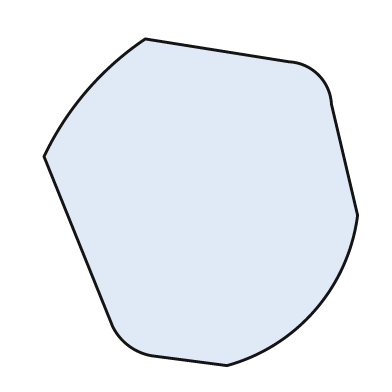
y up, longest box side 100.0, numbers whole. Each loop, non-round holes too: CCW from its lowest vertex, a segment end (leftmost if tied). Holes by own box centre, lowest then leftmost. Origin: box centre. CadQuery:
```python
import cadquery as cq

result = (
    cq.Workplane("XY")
    .moveTo(8.0, -50.0)
    .threePointArc((35.0, -33.0), (48.0, -4.0))
    .lineTo(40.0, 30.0)
    .threePointArc((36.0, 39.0), (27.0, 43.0))
    .lineTo(-17.0, 50.0)
    .threePointArc((-35.0, 34.0), (-48.0, 14.0))
    .lineTo(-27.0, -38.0)
    .threePointArc((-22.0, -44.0), (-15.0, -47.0))
    .close()
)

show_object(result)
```